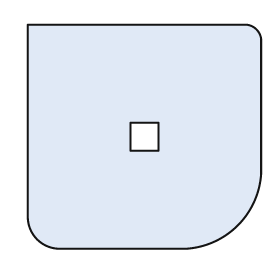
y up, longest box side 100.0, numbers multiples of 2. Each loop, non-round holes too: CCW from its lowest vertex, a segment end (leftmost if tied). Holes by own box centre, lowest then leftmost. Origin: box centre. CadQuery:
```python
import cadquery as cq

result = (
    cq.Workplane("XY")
    .moveTo(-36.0, -48.0)
    .lineTo(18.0, -48.0)
    .threePointArc((40.0, -38.0), (50.0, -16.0))
    .lineTo(50.0, 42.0)
    .threePointArc((48.0, 46.0), (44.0, 48.0))
    .lineTo(-50.0, 48.0)
    .lineTo(-50.0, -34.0)
    .threePointArc((-46.0, -44.0), (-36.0, -48.0))
    .close()
    .moveTo(-6.0, -6.0)
    .lineTo(6.0, -6.0)
    .lineTo(6.0, 6.0)
    .lineTo(-6.0, 6.0)
    .close()
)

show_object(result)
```